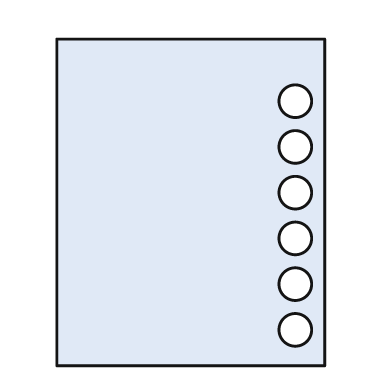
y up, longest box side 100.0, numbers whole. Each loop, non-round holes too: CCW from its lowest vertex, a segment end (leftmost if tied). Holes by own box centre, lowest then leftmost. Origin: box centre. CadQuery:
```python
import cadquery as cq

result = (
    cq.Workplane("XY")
    .moveTo(-41.0, -50.0)
    .lineTo(41.0, -50.0)
    .lineTo(41.0, 50.0)
    .lineTo(-41.0, 50.0)
    .close()
    .moveTo(32.0, -39.0)
    .circle(5.0)
    .moveTo(32.0, -25.0)
    .circle(5.0)
    .moveTo(32.0, -11.0)
    .circle(5.0)
    .moveTo(32.0, 3.0)
    .circle(5.0)
    .moveTo(32.0, 17.0)
    .circle(5.0)
    .moveTo(32.0, 31.0)
    .circle(5.0)
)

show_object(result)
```